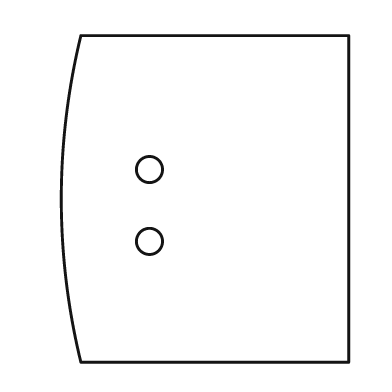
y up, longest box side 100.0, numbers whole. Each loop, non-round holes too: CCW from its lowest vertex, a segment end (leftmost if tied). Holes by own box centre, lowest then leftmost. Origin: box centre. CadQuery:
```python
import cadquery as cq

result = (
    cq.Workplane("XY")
    .moveTo(-38.0, -50.0)
    .lineTo(44.0, -50.0)
    .lineTo(44.0, 50.0)
    .lineTo(-38.0, 50.0)
    .threePointArc((-44.0, 0.0), (-38.0, -50.0))
    .close()
    .moveTo(-17.0, -13.0)
    .circle(4.0)
    .moveTo(-17.0, 9.0)
    .circle(4.0)
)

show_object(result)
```